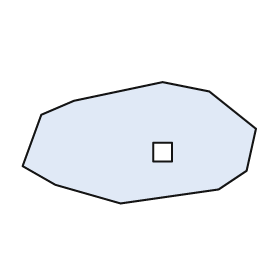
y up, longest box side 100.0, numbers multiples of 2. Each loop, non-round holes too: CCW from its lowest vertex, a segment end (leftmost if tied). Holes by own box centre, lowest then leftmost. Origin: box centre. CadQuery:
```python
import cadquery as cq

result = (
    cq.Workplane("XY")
    .moveTo(-8.0, -26.0)
    .lineTo(34.0, -20.0)
    .lineTo(46.0, -12.0)
    .lineTo(50.0, 6.0)
    .lineTo(30.0, 22.0)
    .lineTo(10.0, 26.0)
    .lineTo(-28.0, 18.0)
    .lineTo(-42.0, 12.0)
    .lineTo(-50.0, -10.0)
    .lineTo(-36.0, -18.0)
    .close()
    .moveTo(6.0, -8.0)
    .lineTo(14.0, -8.0)
    .lineTo(14.0, 0.0)
    .lineTo(6.0, 0.0)
    .close()
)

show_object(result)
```